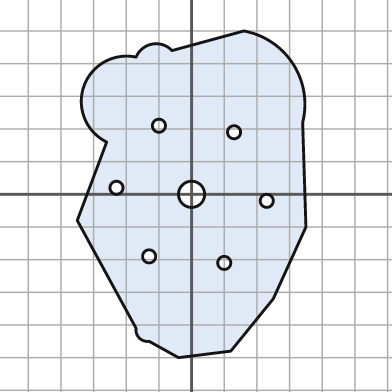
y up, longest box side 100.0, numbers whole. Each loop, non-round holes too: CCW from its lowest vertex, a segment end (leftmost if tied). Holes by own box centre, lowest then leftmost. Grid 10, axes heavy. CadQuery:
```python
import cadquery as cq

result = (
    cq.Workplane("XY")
    .moveTo(-4.0, -50.0)
    .lineTo(12.0, -48.0)
    .lineTo(25.0, -32.0)
    .lineTo(35.0, -10.0)
    .lineTo(34.0, 22.0)
    .threePointArc((31.0, 40.0), (16.0, 50.0))
    .lineTo(-6.0, 44.0)
    .threePointArc((-12.0, 46.0), (-17.0, 42.0))
    .threePointArc((-33.0, 33.0), (-26.0, 16.0))
    .lineTo(-35.0, -8.0)
    .lineTo(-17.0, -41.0)
    .threePointArc((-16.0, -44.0), (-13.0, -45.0))
    .close()
    .moveTo(10.0, -21.0)
    .circle(2.0)
    .moveTo(-13.0, -19.0)
    .circle(2.0)
    .moveTo(23.0, -2.0)
    .circle(2.0)
    .moveTo(0.0, 0.0)
    .circle(4.0)
    .moveTo(-23.0, 2.0)
    .circle(2.0)
    .moveTo(13.0, 19.0)
    .circle(2.0)
    .moveTo(-10.0, 21.0)
    .circle(2.0)
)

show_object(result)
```